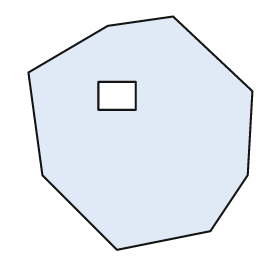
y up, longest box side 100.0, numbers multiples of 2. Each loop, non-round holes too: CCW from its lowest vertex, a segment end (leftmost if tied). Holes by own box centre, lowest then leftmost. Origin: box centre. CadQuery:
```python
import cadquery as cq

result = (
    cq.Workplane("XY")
    .moveTo(-10.0, -50.0)
    .lineTo(30.0, -42.0)
    .lineTo(46.0, -18.0)
    .lineTo(48.0, 18.0)
    .lineTo(14.0, 50.0)
    .lineTo(-14.0, 46.0)
    .lineTo(-48.0, 26.0)
    .lineTo(-42.0, -18.0)
    .close()
    .moveTo(-18.0, 10.0)
    .lineTo(-2.0, 10.0)
    .lineTo(-2.0, 22.0)
    .lineTo(-18.0, 22.0)
    .close()
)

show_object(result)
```